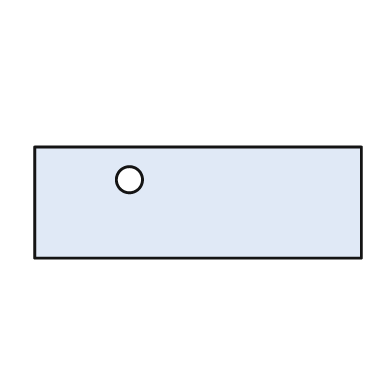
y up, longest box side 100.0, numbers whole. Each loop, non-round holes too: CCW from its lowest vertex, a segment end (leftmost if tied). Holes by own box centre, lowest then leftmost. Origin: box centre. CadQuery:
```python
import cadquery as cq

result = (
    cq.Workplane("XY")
    .moveTo(-50.0, -17.0)
    .lineTo(50.0, -17.0)
    .lineTo(50.0, 17.0)
    .lineTo(-50.0, 17.0)
    .close()
    .moveTo(-21.0, 7.0)
    .circle(4.0)
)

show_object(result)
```